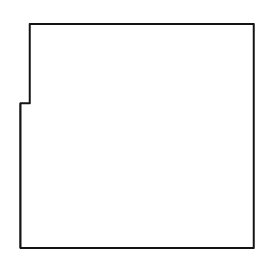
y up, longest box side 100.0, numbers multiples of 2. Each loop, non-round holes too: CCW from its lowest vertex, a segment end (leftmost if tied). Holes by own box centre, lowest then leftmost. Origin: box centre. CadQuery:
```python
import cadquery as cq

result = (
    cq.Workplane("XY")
    .moveTo(-50.0, -48.0)
    .lineTo(50.0, -48.0)
    .lineTo(50.0, 48.0)
    .lineTo(-46.0, 48.0)
    .lineTo(-46.0, 14.0)
    .lineTo(-50.0, 14.0)
    .close()
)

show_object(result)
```